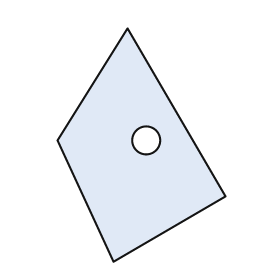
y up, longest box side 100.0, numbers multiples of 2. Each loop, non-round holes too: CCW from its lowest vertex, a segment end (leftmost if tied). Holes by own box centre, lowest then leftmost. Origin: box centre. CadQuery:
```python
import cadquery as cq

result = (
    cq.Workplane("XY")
    .moveTo(-12.0, -50.0)
    .lineTo(36.0, -22.0)
    .lineTo(-6.0, 50.0)
    .lineTo(-36.0, 2.0)
    .close()
    .moveTo(2.0, 2.0)
    .circle(6.0)
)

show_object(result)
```